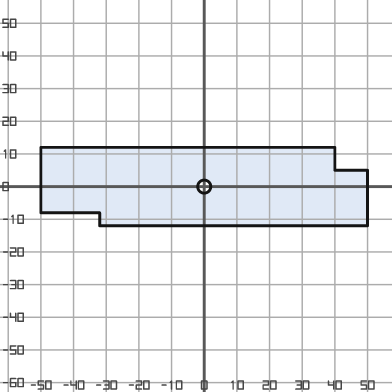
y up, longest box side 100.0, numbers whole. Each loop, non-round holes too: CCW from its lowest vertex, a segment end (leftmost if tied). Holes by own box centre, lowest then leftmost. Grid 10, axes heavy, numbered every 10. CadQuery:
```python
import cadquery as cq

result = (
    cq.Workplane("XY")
    .moveTo(-32.0, -12.0)
    .lineTo(50.0, -12.0)
    .lineTo(50.0, 5.0)
    .lineTo(40.0, 5.0)
    .lineTo(40.0, 12.0)
    .lineTo(-50.0, 12.0)
    .lineTo(-50.0, -8.0)
    .lineTo(-32.0, -8.0)
    .close()
    .moveTo(0.0, 0.0)
    .circle(2.0)
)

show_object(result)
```